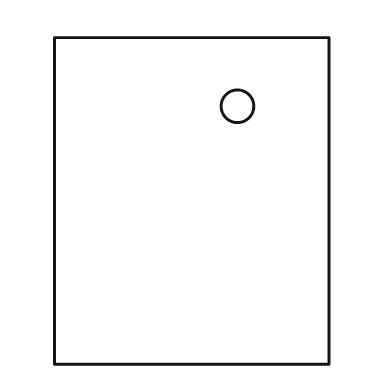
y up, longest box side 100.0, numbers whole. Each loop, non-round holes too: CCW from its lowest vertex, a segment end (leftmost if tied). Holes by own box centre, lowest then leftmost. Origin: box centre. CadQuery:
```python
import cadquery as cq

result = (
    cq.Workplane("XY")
    .moveTo(-42.0, -50.0)
    .lineTo(42.0, -50.0)
    .lineTo(42.0, 50.0)
    .lineTo(-42.0, 50.0)
    .close()
    .moveTo(14.0, 29.0)
    .circle(5.0)
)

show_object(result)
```